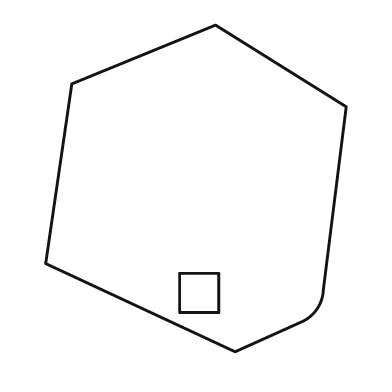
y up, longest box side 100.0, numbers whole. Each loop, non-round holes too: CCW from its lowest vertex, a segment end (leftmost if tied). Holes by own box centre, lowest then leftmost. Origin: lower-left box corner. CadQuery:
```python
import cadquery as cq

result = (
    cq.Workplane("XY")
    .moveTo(58.0, 0.0)
    .lineTo(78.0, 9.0)
    .threePointArc((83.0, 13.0), (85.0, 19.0))
    .lineTo(92.0, 75.0)
    .lineTo(52.0, 100.0)
    .lineTo(8.0, 82.0)
    .lineTo(0.0, 27.0)
    .close()
    .moveTo(41.0, 12.0)
    .lineTo(53.0, 12.0)
    .lineTo(53.0, 24.0)
    .lineTo(41.0, 24.0)
    .close()
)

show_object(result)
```